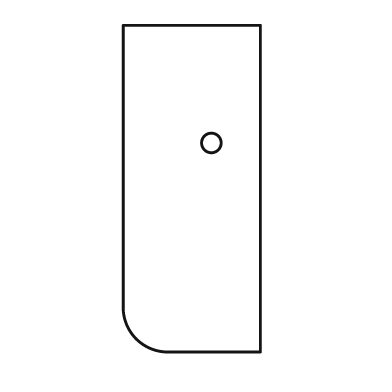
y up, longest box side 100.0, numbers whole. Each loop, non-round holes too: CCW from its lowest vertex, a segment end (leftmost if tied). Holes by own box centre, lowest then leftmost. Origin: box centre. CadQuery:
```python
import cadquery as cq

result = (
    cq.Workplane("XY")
    .moveTo(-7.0, -50.0)
    .lineTo(21.0, -50.0)
    .lineTo(21.0, 50.0)
    .lineTo(-21.0, 50.0)
    .lineTo(-21.0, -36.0)
    .threePointArc((-17.0, -46.0), (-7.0, -50.0))
    .close()
    .moveTo(6.0, 14.0)
    .circle(3.0)
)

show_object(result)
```